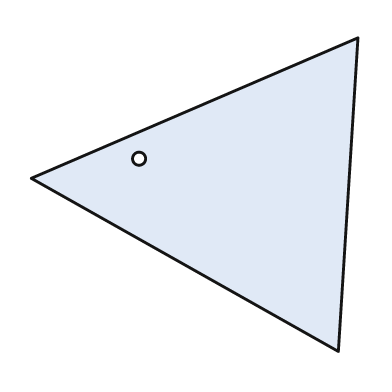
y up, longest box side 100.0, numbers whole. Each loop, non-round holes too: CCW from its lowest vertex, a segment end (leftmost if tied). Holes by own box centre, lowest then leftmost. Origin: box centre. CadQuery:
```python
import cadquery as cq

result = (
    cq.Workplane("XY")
    .moveTo(44.0, -48.0)
    .lineTo(50.0, 48.0)
    .lineTo(-50.0, 5.0)
    .close()
    .moveTo(-17.0, 11.0)
    .circle(2.0)
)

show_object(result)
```